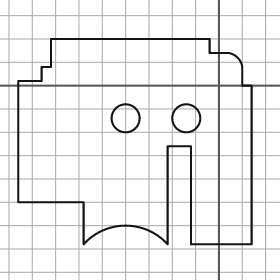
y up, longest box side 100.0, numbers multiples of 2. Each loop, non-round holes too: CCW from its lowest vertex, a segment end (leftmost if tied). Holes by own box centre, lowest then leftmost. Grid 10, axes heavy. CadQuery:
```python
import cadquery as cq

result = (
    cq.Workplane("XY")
    .moveTo(-58.0, -68.0)
    .threePointArc((-40.0, -60.0), (-22.0, -68.0))
    .lineTo(-22.0, -26.0)
    .lineTo(-12.0, -26.0)
    .lineTo(-12.0, -68.0)
    .lineTo(14.0, -68.0)
    .lineTo(14.0, 0.0)
    .lineTo(10.0, 0.0)
    .lineTo(10.0, 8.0)
    .threePointArc((8.0, 12.0), (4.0, 14.0))
    .lineTo(-4.0, 14.0)
    .lineTo(-4.0, 20.0)
    .lineTo(-72.0, 20.0)
    .lineTo(-72.0, 8.0)
    .lineTo(-76.0, 8.0)
    .lineTo(-76.0, 2.0)
    .lineTo(-86.0, 2.0)
    .lineTo(-86.0, -50.0)
    .lineTo(-58.0, -50.0)
    .close()
    .moveTo(-40.0, -14.0)
    .circle(6.0)
    .moveTo(-14.0, -14.0)
    .circle(6.0)
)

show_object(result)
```